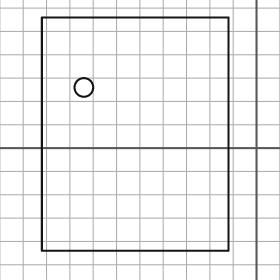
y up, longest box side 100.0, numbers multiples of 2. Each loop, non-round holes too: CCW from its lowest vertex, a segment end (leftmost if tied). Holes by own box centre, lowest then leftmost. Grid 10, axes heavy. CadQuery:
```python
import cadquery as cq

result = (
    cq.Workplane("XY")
    .moveTo(-92.0, -44.0)
    .lineTo(-12.0, -44.0)
    .lineTo(-12.0, 56.0)
    .lineTo(-92.0, 56.0)
    .close()
    .moveTo(-74.0, 26.0)
    .circle(4.0)
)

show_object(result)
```